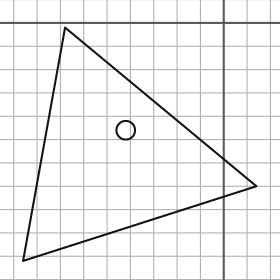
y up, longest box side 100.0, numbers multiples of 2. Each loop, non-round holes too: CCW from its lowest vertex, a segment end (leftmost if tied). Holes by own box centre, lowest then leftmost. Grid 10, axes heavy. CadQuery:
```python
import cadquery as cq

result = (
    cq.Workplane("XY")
    .moveTo(-86.0, -102.0)
    .lineTo(14.0, -70.0)
    .lineTo(-68.0, -2.0)
    .close()
    .moveTo(-42.0, -46.0)
    .circle(4.0)
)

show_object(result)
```